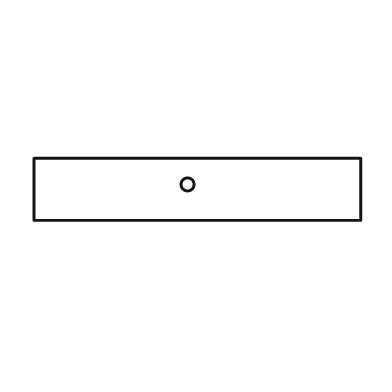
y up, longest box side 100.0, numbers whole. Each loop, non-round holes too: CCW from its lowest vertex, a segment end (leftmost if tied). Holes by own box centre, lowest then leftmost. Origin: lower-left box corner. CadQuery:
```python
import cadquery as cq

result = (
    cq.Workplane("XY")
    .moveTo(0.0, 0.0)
    .lineTo(100.0, 0.0)
    .lineTo(100.0, 19.0)
    .lineTo(0.0, 19.0)
    .close()
    .moveTo(47.0, 11.0)
    .circle(2.0)
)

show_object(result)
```